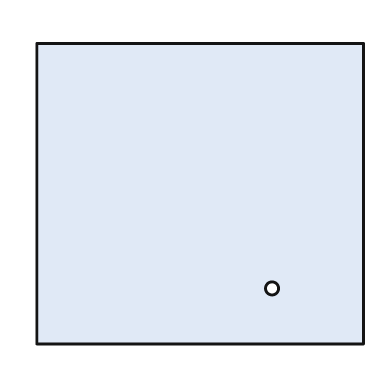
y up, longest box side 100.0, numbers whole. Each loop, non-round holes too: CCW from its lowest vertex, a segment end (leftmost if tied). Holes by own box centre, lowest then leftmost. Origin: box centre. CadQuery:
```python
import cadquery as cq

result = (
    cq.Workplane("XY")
    .moveTo(-50.0, -46.0)
    .lineTo(50.0, -46.0)
    .lineTo(50.0, 46.0)
    .lineTo(-50.0, 46.0)
    .close()
    .moveTo(22.0, -29.0)
    .circle(2.0)
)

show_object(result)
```